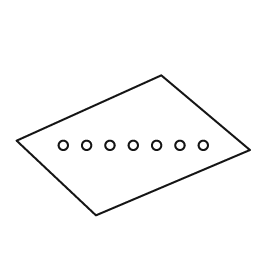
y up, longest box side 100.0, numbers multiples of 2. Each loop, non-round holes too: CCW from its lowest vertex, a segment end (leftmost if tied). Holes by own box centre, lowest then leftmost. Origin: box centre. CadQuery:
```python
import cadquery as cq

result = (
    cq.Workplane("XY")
    .moveTo(-16.0, -30.0)
    .lineTo(50.0, -2.0)
    .lineTo(12.0, 30.0)
    .lineTo(-50.0, 2.0)
    .close()
    .moveTo(-30.0, 0.0)
    .circle(2.0)
    .moveTo(-20.0, 0.0)
    .circle(2.0)
    .moveTo(-10.0, 0.0)
    .circle(2.0)
    .moveTo(0.0, 0.0)
    .circle(2.0)
    .moveTo(10.0, 0.0)
    .circle(2.0)
    .moveTo(20.0, 0.0)
    .circle(2.0)
    .moveTo(30.0, 0.0)
    .circle(2.0)
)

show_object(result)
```